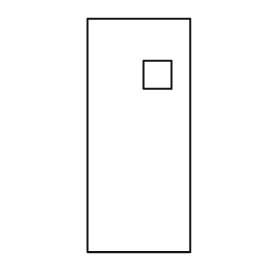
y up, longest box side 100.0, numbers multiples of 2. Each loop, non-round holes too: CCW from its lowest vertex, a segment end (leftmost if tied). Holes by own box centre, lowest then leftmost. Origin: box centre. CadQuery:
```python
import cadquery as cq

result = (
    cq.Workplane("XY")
    .moveTo(-22.0, -50.0)
    .lineTo(22.0, -50.0)
    .lineTo(22.0, 50.0)
    .lineTo(-22.0, 50.0)
    .close()
    .moveTo(2.0, 20.0)
    .lineTo(14.0, 20.0)
    .lineTo(14.0, 32.0)
    .lineTo(2.0, 32.0)
    .close()
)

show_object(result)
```